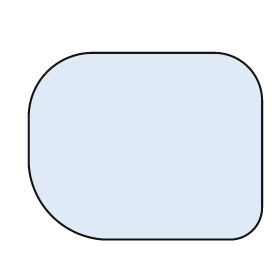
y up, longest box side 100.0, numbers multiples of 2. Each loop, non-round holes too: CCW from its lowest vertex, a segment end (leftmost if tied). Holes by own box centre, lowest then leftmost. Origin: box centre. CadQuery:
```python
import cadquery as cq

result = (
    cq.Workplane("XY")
    .moveTo(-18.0, -40.0)
    .lineTo(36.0, -40.0)
    .threePointArc((46.0, -36.0), (50.0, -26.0))
    .lineTo(50.0, 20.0)
    .threePointArc((44.0, 34.0), (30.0, 40.0))
    .lineTo(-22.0, 40.0)
    .threePointArc((-42.0, 32.0), (-50.0, 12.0))
    .lineTo(-50.0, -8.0)
    .threePointArc((-40.0, -30.0), (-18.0, -40.0))
    .close()
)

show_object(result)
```